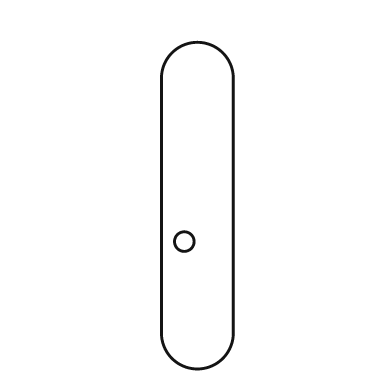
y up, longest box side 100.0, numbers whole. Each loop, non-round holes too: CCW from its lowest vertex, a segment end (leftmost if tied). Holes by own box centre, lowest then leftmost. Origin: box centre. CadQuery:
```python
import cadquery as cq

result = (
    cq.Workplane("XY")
    .moveTo(-11.0, -39.0)
    .threePointArc((0.0, -50.0), (11.0, -39.0))
    .lineTo(11.0, 39.0)
    .threePointArc((0.0, 50.0), (-11.0, 39.0))
    .close()
    .moveTo(-4.0, -11.0)
    .circle(3.0)
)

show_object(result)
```